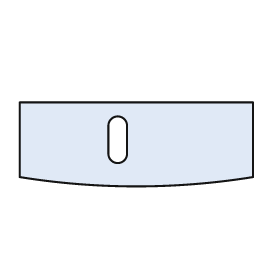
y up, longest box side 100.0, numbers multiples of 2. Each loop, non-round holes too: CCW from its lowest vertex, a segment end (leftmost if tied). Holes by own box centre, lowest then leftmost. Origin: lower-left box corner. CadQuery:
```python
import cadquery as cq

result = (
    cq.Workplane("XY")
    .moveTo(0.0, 4.0)
    .threePointArc((50.0, 0.0), (100.0, 4.0))
    .lineTo(100.0, 36.0)
    .lineTo(0.0, 36.0)
    .close()
    .moveTo(38.0, 14.0)
    .threePointArc((42.0, 10.0), (46.0, 14.0))
    .lineTo(46.0, 26.0)
    .threePointArc((42.0, 30.0), (38.0, 26.0))
    .close()
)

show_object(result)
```